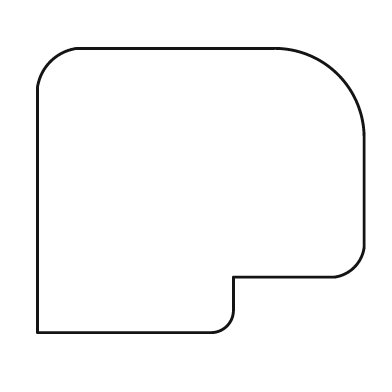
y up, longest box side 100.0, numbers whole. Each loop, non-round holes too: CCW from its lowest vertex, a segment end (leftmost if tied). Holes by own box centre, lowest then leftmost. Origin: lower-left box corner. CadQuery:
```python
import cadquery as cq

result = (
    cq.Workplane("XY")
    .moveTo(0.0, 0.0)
    .lineTo(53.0, 0.0)
    .threePointArc((58.0, 2.0), (60.0, 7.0))
    .lineTo(60.0, 17.0)
    .lineTo(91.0, 17.0)
    .threePointArc((97.0, 20.0), (100.0, 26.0))
    .lineTo(100.0, 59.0)
    .threePointArc((92.0, 79.0), (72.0, 87.0))
    .lineTo(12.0, 87.0)
    .threePointArc((4.0, 83.0), (0.0, 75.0))
    .close()
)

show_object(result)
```